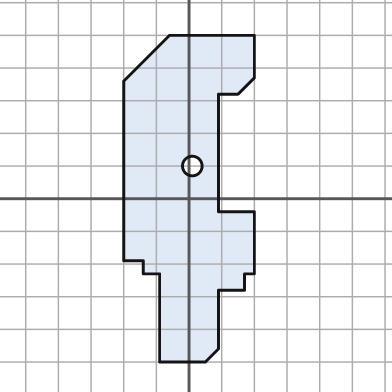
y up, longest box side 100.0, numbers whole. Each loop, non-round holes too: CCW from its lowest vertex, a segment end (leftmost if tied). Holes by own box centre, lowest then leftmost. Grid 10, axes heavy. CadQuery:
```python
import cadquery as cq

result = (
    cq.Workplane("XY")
    .moveTo(-9.0, -50.0)
    .lineTo(5.0, -50.0)
    .lineTo(9.0, -46.0)
    .lineTo(9.0, -28.0)
    .lineTo(17.0, -28.0)
    .lineTo(17.0, -23.0)
    .lineTo(20.0, -23.0)
    .lineTo(20.0, -4.0)
    .lineTo(9.0, -4.0)
    .lineTo(9.0, 32.0)
    .lineTo(15.0, 32.0)
    .lineTo(20.0, 37.0)
    .lineTo(20.0, 50.0)
    .lineTo(-6.0, 50.0)
    .lineTo(-20.0, 36.0)
    .lineTo(-20.0, -19.0)
    .lineTo(-14.0, -19.0)
    .lineTo(-14.0, -23.0)
    .lineTo(-9.0, -23.0)
    .close()
    .moveTo(1.0, 10.0)
    .circle(3.0)
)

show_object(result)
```